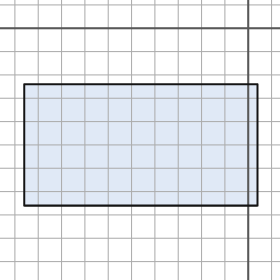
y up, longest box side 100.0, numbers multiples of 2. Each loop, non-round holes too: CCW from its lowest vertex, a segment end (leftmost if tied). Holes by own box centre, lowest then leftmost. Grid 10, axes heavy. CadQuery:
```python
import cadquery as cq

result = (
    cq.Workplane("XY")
    .moveTo(-96.0, -76.0)
    .lineTo(4.0, -76.0)
    .lineTo(4.0, -24.0)
    .lineTo(-96.0, -24.0)
    .close()
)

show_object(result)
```